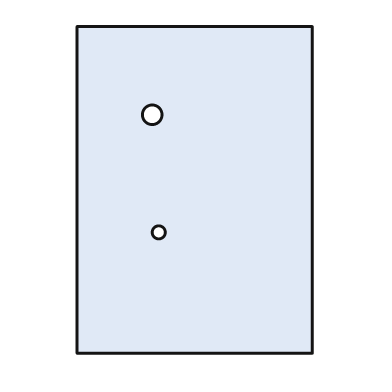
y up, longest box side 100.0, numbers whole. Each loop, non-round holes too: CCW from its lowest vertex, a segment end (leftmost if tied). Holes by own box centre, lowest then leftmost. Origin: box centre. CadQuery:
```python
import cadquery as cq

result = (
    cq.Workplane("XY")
    .moveTo(-36.0, -50.0)
    .lineTo(36.0, -50.0)
    .lineTo(36.0, 50.0)
    .lineTo(-36.0, 50.0)
    .close()
    .moveTo(-11.0, -13.0)
    .circle(2.0)
    .moveTo(-13.0, 23.0)
    .circle(3.0)
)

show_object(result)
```